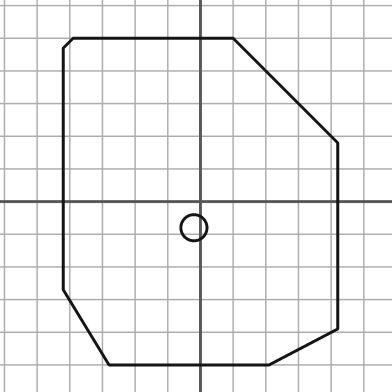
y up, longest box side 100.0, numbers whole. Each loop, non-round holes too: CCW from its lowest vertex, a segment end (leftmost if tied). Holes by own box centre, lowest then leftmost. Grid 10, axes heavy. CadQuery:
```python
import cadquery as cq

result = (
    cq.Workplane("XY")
    .moveTo(-28.0, -50.0)
    .lineTo(21.0, -50.0)
    .lineTo(42.0, -39.0)
    .lineTo(42.0, 18.0)
    .lineTo(10.0, 50.0)
    .lineTo(-39.0, 50.0)
    .lineTo(-42.0, 47.0)
    .lineTo(-42.0, -27.0)
    .close()
    .moveTo(-2.0, -8.0)
    .circle(4.0)
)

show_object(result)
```